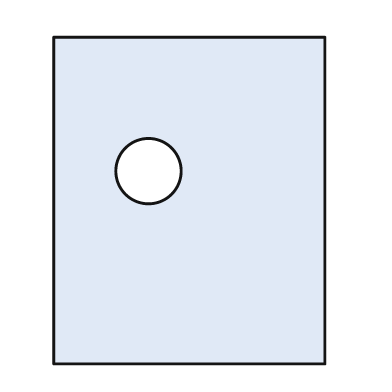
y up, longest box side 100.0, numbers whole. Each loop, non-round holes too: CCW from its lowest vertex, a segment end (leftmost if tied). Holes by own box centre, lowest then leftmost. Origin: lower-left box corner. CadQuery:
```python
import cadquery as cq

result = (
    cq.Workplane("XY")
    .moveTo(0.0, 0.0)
    .lineTo(83.0, 0.0)
    .lineTo(83.0, 100.0)
    .lineTo(0.0, 100.0)
    .close()
    .moveTo(29.0, 59.0)
    .circle(10.0)
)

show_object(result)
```